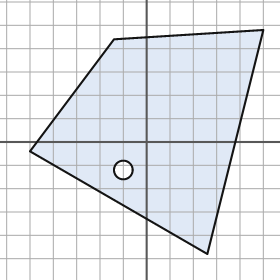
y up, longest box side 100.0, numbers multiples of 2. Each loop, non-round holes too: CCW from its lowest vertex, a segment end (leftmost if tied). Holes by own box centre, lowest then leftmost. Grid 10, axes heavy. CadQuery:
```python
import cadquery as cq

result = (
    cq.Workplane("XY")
    .moveTo(26.0, -48.0)
    .lineTo(50.0, 48.0)
    .lineTo(-14.0, 44.0)
    .lineTo(-50.0, -4.0)
    .close()
    .moveTo(-10.0, -12.0)
    .circle(4.0)
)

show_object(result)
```